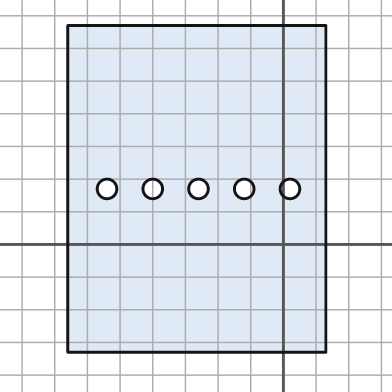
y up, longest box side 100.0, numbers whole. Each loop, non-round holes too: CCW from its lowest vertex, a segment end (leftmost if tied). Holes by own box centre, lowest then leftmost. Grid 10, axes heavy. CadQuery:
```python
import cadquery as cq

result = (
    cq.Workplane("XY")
    .moveTo(-66.0, -33.0)
    .lineTo(13.0, -33.0)
    .lineTo(13.0, 67.0)
    .lineTo(-66.0, 67.0)
    .close()
    .moveTo(-54.0, 17.0)
    .circle(3.0)
    .moveTo(-40.0, 17.0)
    .circle(3.0)
    .moveTo(-26.0, 17.0)
    .circle(3.0)
    .moveTo(-12.0, 17.0)
    .circle(3.0)
    .moveTo(2.0, 17.0)
    .circle(3.0)
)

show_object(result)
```